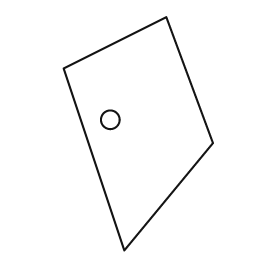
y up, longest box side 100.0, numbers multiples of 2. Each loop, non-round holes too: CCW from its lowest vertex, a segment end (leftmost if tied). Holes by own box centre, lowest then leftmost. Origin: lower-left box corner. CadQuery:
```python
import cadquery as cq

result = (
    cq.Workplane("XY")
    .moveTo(26.0, 0.0)
    .lineTo(64.0, 46.0)
    .lineTo(44.0, 100.0)
    .lineTo(0.0, 78.0)
    .close()
    .moveTo(20.0, 56.0)
    .circle(4.0)
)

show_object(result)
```